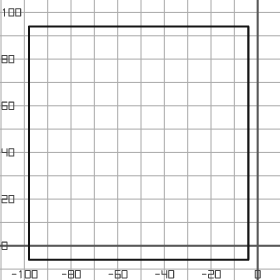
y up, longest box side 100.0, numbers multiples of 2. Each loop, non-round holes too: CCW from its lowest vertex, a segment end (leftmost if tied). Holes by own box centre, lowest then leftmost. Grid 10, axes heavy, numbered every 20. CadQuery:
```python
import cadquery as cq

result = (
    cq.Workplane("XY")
    .moveTo(-98.0, -6.0)
    .lineTo(-4.0, -6.0)
    .lineTo(-4.0, 94.0)
    .lineTo(-98.0, 94.0)
    .close()
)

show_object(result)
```